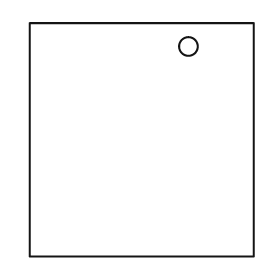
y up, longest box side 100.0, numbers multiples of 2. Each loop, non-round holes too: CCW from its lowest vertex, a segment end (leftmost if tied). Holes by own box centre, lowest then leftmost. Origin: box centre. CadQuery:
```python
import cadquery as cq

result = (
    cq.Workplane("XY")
    .moveTo(-48.0, -50.0)
    .lineTo(48.0, -50.0)
    .lineTo(48.0, 50.0)
    .lineTo(-48.0, 50.0)
    .close()
    .moveTo(20.0, 40.0)
    .circle(4.0)
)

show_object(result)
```